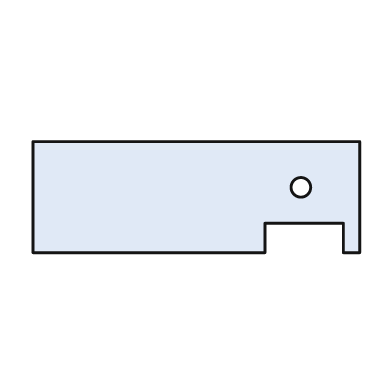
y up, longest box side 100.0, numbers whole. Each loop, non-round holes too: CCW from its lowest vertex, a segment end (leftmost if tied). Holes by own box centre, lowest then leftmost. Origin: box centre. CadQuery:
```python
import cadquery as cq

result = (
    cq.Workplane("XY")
    .moveTo(-50.0, -17.0)
    .lineTo(21.0, -17.0)
    .lineTo(21.0, -8.0)
    .lineTo(45.0, -8.0)
    .lineTo(45.0, -17.0)
    .lineTo(50.0, -17.0)
    .lineTo(50.0, 17.0)
    .lineTo(-50.0, 17.0)
    .close()
    .moveTo(32.0, 3.0)
    .circle(3.0)
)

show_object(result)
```